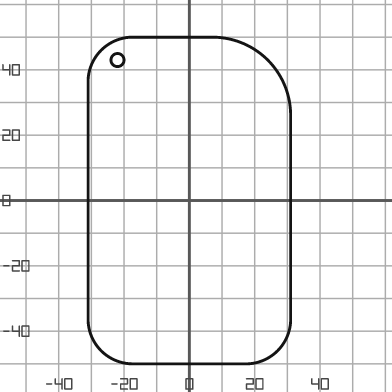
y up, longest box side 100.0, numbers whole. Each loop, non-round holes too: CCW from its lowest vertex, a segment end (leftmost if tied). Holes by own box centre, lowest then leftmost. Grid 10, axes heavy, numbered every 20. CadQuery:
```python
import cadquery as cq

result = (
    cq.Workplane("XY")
    .moveTo(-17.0, -50.0)
    .lineTo(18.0, -50.0)
    .threePointArc((27.0, -46.0), (31.0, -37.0))
    .lineTo(31.0, 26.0)
    .threePointArc((24.0, 43.0), (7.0, 50.0))
    .lineTo(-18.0, 50.0)
    .threePointArc((-27.0, 46.0), (-31.0, 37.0))
    .lineTo(-31.0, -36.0)
    .threePointArc((-27.0, -46.0), (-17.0, -50.0))
    .close()
    .moveTo(-22.0, 43.0)
    .circle(2.0)
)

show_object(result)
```